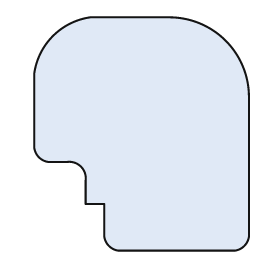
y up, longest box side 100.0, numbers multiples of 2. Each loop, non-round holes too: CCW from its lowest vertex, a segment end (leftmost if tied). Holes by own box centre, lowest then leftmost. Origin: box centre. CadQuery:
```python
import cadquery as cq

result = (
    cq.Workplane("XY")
    .moveTo(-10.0, -50.0)
    .lineTo(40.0, -50.0)
    .threePointArc((44.0, -48.0), (46.0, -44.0))
    .lineTo(46.0, 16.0)
    .threePointArc((36.0, 40.0), (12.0, 50.0))
    .lineTo(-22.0, 50.0)
    .threePointArc((-38.0, 42.0), (-46.0, 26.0))
    .lineTo(-46.0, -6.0)
    .threePointArc((-44.0, -10.0), (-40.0, -12.0))
    .lineTo(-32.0, -12.0)
    .threePointArc((-26.0, -14.0), (-24.0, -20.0))
    .lineTo(-24.0, -30.0)
    .lineTo(-16.0, -30.0)
    .lineTo(-16.0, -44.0)
    .threePointArc((-14.0, -48.0), (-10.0, -50.0))
    .close()
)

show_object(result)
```